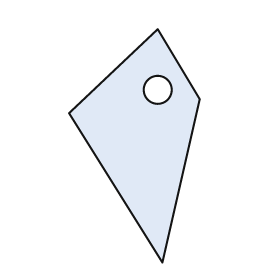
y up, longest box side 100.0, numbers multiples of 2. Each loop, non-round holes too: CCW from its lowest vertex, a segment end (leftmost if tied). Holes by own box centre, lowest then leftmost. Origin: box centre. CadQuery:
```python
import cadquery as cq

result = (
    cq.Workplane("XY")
    .moveTo(12.0, -50.0)
    .lineTo(28.0, 20.0)
    .lineTo(10.0, 50.0)
    .lineTo(-28.0, 14.0)
    .close()
    .moveTo(10.0, 24.0)
    .circle(6.0)
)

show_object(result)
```